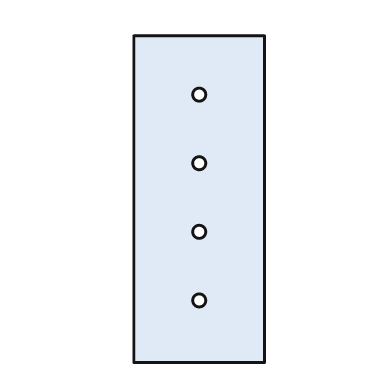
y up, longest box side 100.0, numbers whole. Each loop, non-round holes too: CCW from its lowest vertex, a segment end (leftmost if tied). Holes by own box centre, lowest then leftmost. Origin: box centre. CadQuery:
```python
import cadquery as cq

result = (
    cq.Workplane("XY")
    .moveTo(-20.0, -50.0)
    .lineTo(20.0, -50.0)
    .lineTo(20.0, 50.0)
    .lineTo(-20.0, 50.0)
    .close()
    .moveTo(0.0, -31.0)
    .circle(2.0)
    .moveTo(0.0, -10.0)
    .circle(2.0)
    .moveTo(0.0, 11.0)
    .circle(2.0)
    .moveTo(0.0, 32.0)
    .circle(2.0)
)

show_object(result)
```